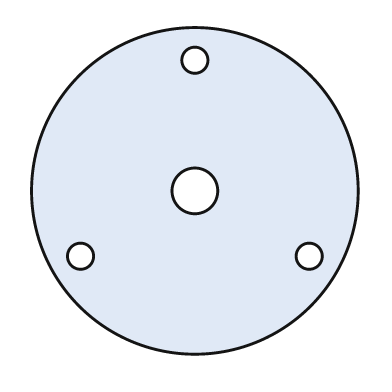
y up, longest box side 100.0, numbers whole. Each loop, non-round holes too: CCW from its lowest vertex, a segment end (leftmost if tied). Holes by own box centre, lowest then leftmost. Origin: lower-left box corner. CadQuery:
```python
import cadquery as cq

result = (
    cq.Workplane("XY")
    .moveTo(50.0, 50.0)
    .circle(50.0)
    .moveTo(15.0, 30.0)
    .circle(4.0)
    .moveTo(85.0, 30.0)
    .circle(4.0)
    .moveTo(50.0, 50.0)
    .circle(7.0)
    .moveTo(50.0, 90.0)
    .circle(4.0)
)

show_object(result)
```